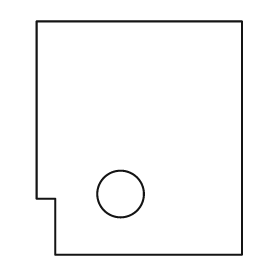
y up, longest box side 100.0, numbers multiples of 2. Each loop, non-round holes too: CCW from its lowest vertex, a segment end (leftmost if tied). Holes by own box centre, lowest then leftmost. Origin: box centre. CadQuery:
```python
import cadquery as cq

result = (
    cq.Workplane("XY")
    .moveTo(-36.0, -50.0)
    .lineTo(44.0, -50.0)
    .lineTo(44.0, 50.0)
    .lineTo(-44.0, 50.0)
    .lineTo(-44.0, -26.0)
    .lineTo(-36.0, -26.0)
    .close()
    .moveTo(-8.0, -24.0)
    .circle(10.0)
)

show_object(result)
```